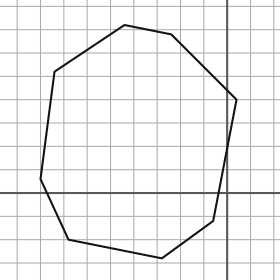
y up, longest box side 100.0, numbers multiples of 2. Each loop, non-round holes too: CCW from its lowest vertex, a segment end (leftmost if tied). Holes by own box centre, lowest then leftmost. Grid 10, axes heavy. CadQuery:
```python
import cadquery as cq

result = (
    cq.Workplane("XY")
    .moveTo(-28.0, -28.0)
    .lineTo(-6.0, -12.0)
    .lineTo(4.0, 40.0)
    .lineTo(-24.0, 68.0)
    .lineTo(-44.0, 72.0)
    .lineTo(-74.0, 52.0)
    .lineTo(-80.0, 6.0)
    .lineTo(-68.0, -20.0)
    .close()
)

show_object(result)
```